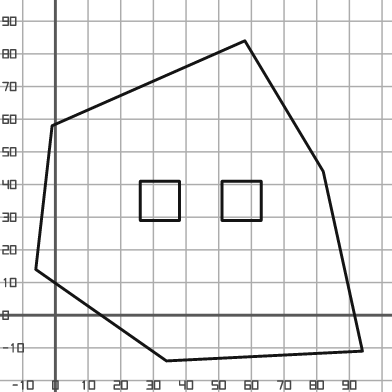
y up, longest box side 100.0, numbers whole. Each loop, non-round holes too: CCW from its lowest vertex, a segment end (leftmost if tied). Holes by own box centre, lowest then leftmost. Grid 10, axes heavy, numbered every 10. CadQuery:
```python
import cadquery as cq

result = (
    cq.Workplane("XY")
    .moveTo(34.0, -14.0)
    .lineTo(94.0, -11.0)
    .lineTo(82.0, 44.0)
    .lineTo(58.0, 84.0)
    .lineTo(-1.0, 58.0)
    .lineTo(-6.0, 14.0)
    .close()
    .moveTo(26.0, 29.0)
    .lineTo(38.0, 29.0)
    .lineTo(38.0, 41.0)
    .lineTo(26.0, 41.0)
    .close()
    .moveTo(51.0, 29.0)
    .lineTo(63.0, 29.0)
    .lineTo(63.0, 41.0)
    .lineTo(51.0, 41.0)
    .close()
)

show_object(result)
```